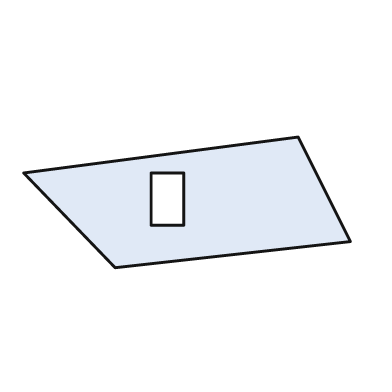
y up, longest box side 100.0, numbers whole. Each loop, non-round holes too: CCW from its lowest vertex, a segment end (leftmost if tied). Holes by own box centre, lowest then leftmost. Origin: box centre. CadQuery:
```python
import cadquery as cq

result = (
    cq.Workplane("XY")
    .moveTo(-22.0, -20.0)
    .lineTo(50.0, -12.0)
    .lineTo(34.0, 20.0)
    .lineTo(-50.0, 9.0)
    .close()
    .moveTo(-11.0, -7.0)
    .lineTo(-1.0, -7.0)
    .lineTo(-1.0, 9.0)
    .lineTo(-11.0, 9.0)
    .close()
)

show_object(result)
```